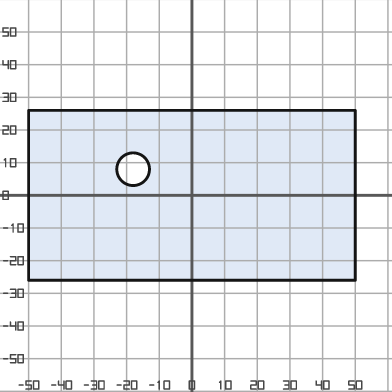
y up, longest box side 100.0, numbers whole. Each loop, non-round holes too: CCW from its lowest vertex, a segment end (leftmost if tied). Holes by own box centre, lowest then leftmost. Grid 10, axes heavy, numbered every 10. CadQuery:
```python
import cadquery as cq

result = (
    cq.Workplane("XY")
    .moveTo(-50.0, -26.0)
    .lineTo(50.0, -26.0)
    .lineTo(50.0, 26.0)
    .lineTo(-50.0, 26.0)
    .close()
    .moveTo(-18.0, 8.0)
    .circle(5.0)
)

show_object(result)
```